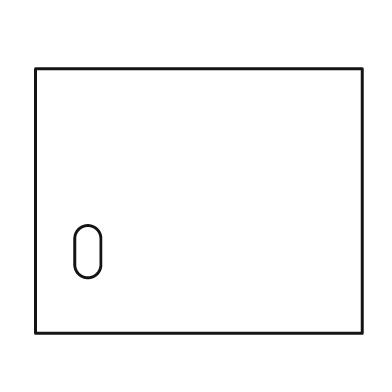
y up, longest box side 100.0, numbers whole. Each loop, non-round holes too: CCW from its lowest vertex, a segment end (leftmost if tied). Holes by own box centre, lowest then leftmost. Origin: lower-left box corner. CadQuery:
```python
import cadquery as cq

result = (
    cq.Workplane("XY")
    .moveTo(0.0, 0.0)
    .lineTo(100.0, 0.0)
    .lineTo(100.0, 81.0)
    .lineTo(0.0, 81.0)
    .close()
    .moveTo(12.0, 21.0)
    .threePointArc((16.0, 17.0), (20.0, 21.0))
    .lineTo(20.0, 29.0)
    .threePointArc((16.0, 33.0), (12.0, 29.0))
    .close()
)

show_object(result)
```